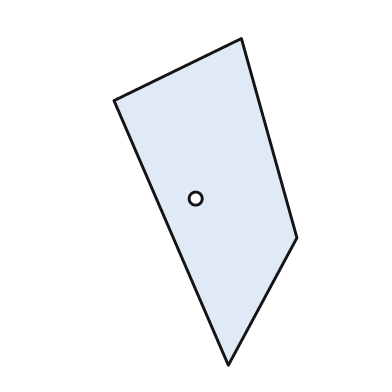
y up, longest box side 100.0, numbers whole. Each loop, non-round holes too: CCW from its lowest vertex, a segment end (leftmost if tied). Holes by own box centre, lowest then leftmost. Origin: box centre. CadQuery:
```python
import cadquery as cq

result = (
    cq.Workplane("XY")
    .moveTo(7.0, -50.0)
    .lineTo(28.0, -11.0)
    .lineTo(11.0, 50.0)
    .lineTo(-28.0, 31.0)
    .close()
    .moveTo(-3.0, 1.0)
    .circle(2.0)
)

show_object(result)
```